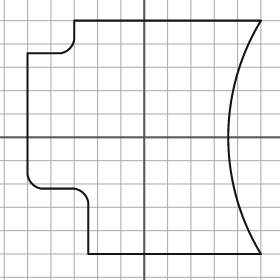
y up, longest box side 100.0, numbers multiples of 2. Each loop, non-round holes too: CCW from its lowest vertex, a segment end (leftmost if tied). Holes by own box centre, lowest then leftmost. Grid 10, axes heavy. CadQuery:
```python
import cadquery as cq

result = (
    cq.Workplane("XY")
    .moveTo(-24.0, -50.0)
    .lineTo(50.0, -50.0)
    .threePointArc((36.0, 0.0), (50.0, 50.0))
    .lineTo(-30.0, 50.0)
    .lineTo(-30.0, 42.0)
    .threePointArc((-32.0, 38.0), (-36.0, 36.0))
    .lineTo(-50.0, 36.0)
    .lineTo(-50.0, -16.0)
    .threePointArc((-48.0, -20.0), (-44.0, -22.0))
    .lineTo(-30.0, -22.0)
    .threePointArc((-26.0, -24.0), (-24.0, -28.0))
    .close()
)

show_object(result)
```